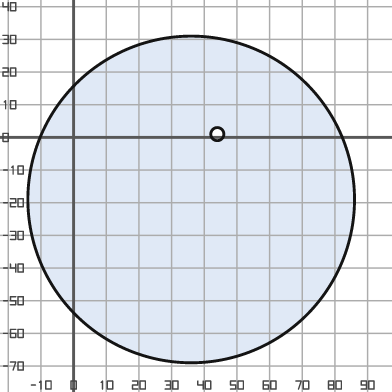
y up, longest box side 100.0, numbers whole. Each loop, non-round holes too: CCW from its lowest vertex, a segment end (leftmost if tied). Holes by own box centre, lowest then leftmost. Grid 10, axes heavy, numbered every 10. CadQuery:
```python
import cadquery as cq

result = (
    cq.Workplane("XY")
    .moveTo(36.0, -19.0)
    .circle(50.0)
    .moveTo(44.0, 1.0)
    .circle(2.0)
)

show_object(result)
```